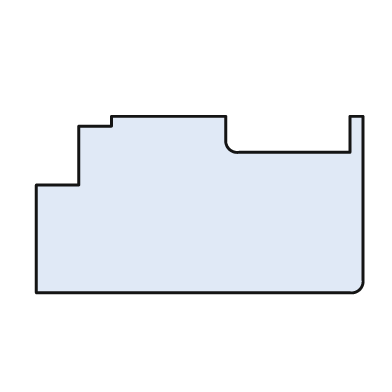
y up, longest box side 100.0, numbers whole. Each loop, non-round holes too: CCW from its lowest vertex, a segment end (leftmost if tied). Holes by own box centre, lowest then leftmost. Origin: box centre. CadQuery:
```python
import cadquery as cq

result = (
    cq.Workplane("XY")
    .moveTo(-50.0, -27.0)
    .lineTo(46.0, -27.0)
    .threePointArc((49.0, -26.0), (50.0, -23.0))
    .lineTo(50.0, 27.0)
    .lineTo(46.0, 27.0)
    .lineTo(46.0, 16.0)
    .lineTo(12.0, 16.0)
    .threePointArc((9.0, 17.0), (8.0, 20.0))
    .lineTo(8.0, 27.0)
    .lineTo(-27.0, 27.0)
    .lineTo(-27.0, 24.0)
    .lineTo(-37.0, 24.0)
    .lineTo(-37.0, 6.0)
    .lineTo(-50.0, 6.0)
    .close()
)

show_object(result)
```